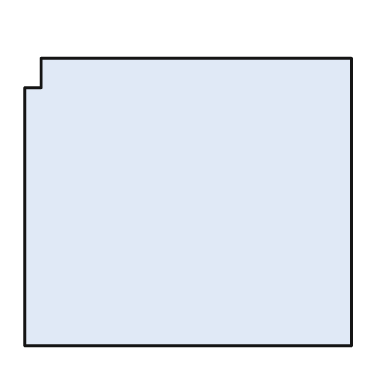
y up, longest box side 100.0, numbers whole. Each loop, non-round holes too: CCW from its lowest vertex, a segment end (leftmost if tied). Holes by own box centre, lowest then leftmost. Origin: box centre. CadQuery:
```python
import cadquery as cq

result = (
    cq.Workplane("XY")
    .moveTo(-50.0, -44.0)
    .lineTo(50.0, -44.0)
    .lineTo(50.0, 44.0)
    .lineTo(-45.0, 44.0)
    .lineTo(-45.0, 35.0)
    .lineTo(-50.0, 35.0)
    .close()
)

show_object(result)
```